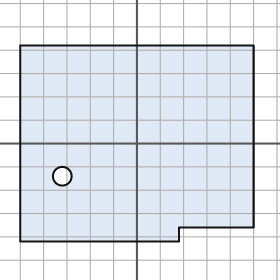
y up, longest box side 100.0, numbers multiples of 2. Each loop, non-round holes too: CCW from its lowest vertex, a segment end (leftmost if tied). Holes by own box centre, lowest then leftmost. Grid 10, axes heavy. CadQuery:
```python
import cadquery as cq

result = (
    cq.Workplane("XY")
    .moveTo(-50.0, -42.0)
    .lineTo(18.0, -42.0)
    .lineTo(18.0, -36.0)
    .lineTo(50.0, -36.0)
    .lineTo(50.0, 42.0)
    .lineTo(-50.0, 42.0)
    .close()
    .moveTo(-32.0, -14.0)
    .circle(4.0)
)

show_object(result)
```